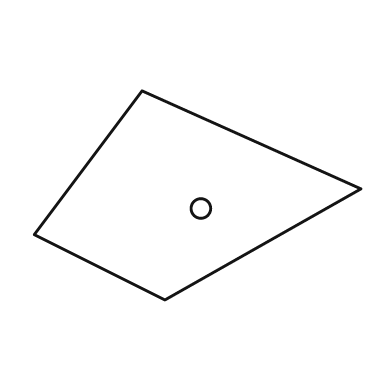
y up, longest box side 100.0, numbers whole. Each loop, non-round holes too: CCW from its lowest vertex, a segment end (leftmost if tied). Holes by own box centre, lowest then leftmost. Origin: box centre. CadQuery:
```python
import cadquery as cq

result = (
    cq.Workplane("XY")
    .moveTo(-10.0, -32.0)
    .lineTo(50.0, 2.0)
    .lineTo(-17.0, 32.0)
    .lineTo(-50.0, -12.0)
    .close()
    .moveTo(1.0, -4.0)
    .circle(3.0)
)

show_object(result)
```